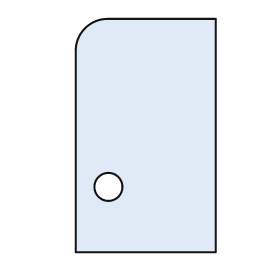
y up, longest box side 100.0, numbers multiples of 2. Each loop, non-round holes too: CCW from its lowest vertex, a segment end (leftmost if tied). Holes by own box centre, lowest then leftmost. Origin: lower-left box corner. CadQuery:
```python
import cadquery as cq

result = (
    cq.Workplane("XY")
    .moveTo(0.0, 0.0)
    .lineTo(60.0, 0.0)
    .lineTo(60.0, 100.0)
    .lineTo(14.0, 100.0)
    .threePointArc((4.0, 96.0), (0.0, 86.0))
    .close()
    .moveTo(14.0, 28.0)
    .circle(6.0)
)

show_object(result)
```